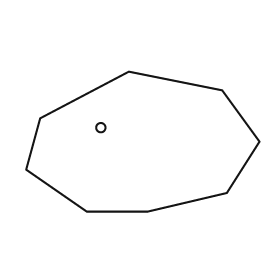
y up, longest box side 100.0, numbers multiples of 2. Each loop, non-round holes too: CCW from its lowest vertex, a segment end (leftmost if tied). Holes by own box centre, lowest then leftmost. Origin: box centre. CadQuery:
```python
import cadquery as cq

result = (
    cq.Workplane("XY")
    .moveTo(-24.0, -30.0)
    .lineTo(2.0, -30.0)
    .lineTo(36.0, -22.0)
    .lineTo(50.0, 0.0)
    .lineTo(34.0, 22.0)
    .lineTo(-6.0, 30.0)
    .lineTo(-44.0, 10.0)
    .lineTo(-50.0, -12.0)
    .close()
    .moveTo(-18.0, 6.0)
    .circle(2.0)
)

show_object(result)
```